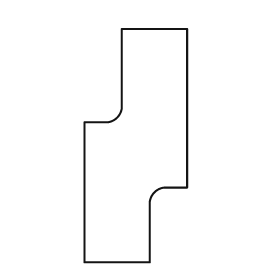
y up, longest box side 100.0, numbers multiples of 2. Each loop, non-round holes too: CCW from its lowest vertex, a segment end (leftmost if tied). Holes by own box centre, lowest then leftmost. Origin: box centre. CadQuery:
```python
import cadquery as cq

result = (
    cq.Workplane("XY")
    .moveTo(-22.0, -50.0)
    .lineTo(6.0, -50.0)
    .lineTo(6.0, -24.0)
    .threePointArc((8.0, -20.0), (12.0, -18.0))
    .lineTo(22.0, -18.0)
    .lineTo(22.0, 50.0)
    .lineTo(-6.0, 50.0)
    .lineTo(-6.0, 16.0)
    .threePointArc((-8.0, 12.0), (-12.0, 10.0))
    .lineTo(-22.0, 10.0)
    .close()
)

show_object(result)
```